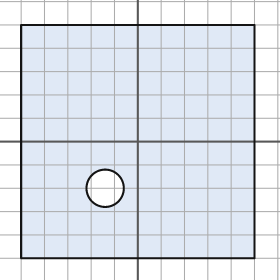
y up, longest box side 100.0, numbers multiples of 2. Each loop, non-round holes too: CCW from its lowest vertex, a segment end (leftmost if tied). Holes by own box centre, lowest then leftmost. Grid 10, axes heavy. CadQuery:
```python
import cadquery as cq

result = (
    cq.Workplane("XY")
    .moveTo(-50.0, -50.0)
    .lineTo(50.0, -50.0)
    .lineTo(50.0, 50.0)
    .lineTo(-50.0, 50.0)
    .close()
    .moveTo(-14.0, -20.0)
    .circle(8.0)
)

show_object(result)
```